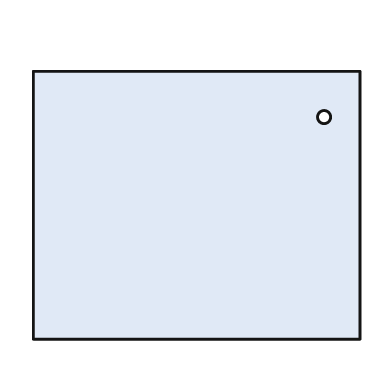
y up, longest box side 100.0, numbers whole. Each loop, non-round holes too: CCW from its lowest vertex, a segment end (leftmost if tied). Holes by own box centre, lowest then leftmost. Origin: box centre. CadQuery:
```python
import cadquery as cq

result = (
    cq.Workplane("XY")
    .moveTo(-50.0, -41.0)
    .lineTo(50.0, -41.0)
    .lineTo(50.0, 41.0)
    .lineTo(-50.0, 41.0)
    .close()
    .moveTo(39.0, 27.0)
    .circle(2.0)
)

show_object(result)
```